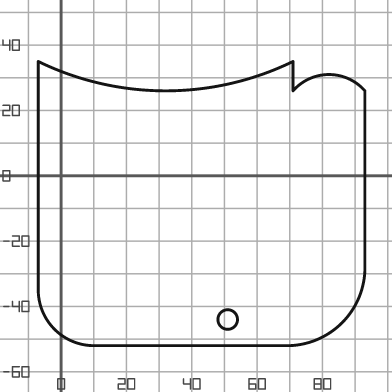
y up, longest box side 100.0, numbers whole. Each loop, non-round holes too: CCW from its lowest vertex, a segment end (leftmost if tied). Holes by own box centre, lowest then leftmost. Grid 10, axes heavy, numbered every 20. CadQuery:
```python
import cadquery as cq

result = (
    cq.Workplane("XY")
    .moveTo(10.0, -52.0)
    .lineTo(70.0, -52.0)
    .threePointArc((86.0, -45.0), (93.0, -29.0))
    .lineTo(93.0, 26.0)
    .threePointArc((82.0, 31.0), (71.0, 26.0))
    .lineTo(71.0, 35.0)
    .threePointArc((32.0, 26.0), (-7.0, 35.0))
    .lineTo(-7.0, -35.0)
    .threePointArc((-2.0, -47.0), (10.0, -52.0))
    .close()
    .moveTo(51.0, -44.0)
    .circle(3.0)
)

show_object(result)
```